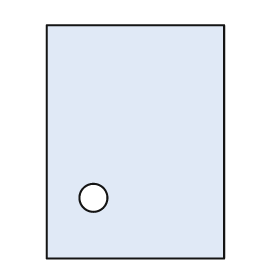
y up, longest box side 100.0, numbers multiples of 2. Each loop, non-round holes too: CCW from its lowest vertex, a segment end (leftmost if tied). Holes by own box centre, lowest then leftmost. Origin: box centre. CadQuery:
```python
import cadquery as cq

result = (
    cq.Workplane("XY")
    .moveTo(-38.0, -50.0)
    .lineTo(38.0, -50.0)
    .lineTo(38.0, 50.0)
    .lineTo(-38.0, 50.0)
    .close()
    .moveTo(-18.0, -24.0)
    .circle(6.0)
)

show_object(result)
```